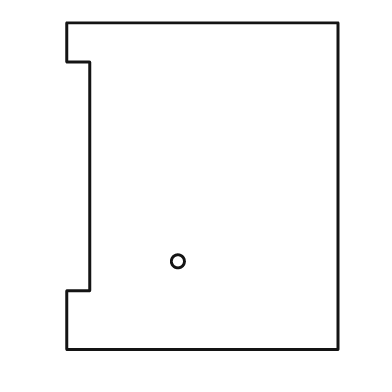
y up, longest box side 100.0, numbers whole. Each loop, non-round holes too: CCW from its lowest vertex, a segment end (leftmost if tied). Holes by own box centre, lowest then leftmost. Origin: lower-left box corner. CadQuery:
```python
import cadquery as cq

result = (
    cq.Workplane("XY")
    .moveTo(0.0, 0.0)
    .lineTo(83.0, 0.0)
    .lineTo(83.0, 100.0)
    .lineTo(0.0, 100.0)
    .lineTo(0.0, 88.0)
    .lineTo(7.0, 88.0)
    .lineTo(7.0, 18.0)
    .lineTo(0.0, 18.0)
    .close()
    .moveTo(34.0, 27.0)
    .circle(2.0)
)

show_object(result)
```